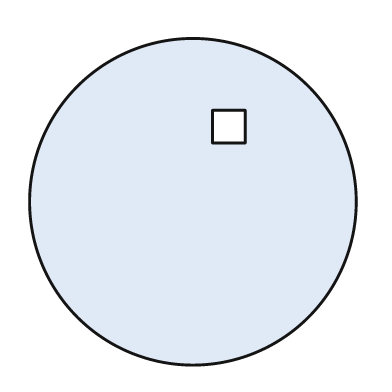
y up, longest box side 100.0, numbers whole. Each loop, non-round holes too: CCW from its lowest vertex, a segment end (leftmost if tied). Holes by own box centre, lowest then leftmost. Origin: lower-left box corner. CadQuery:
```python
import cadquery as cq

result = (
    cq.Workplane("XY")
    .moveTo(50.0, 50.0)
    .circle(50.0)
    .moveTo(56.0, 68.0)
    .lineTo(66.0, 68.0)
    .lineTo(66.0, 78.0)
    .lineTo(56.0, 78.0)
    .close()
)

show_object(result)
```